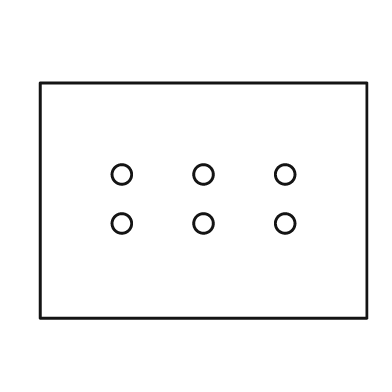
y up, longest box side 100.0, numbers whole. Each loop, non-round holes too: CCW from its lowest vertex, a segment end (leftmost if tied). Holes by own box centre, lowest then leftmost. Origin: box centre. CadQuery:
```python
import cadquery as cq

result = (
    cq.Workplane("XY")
    .moveTo(-50.0, -36.0)
    .lineTo(50.0, -36.0)
    .lineTo(50.0, 36.0)
    .lineTo(-50.0, 36.0)
    .close()
    .moveTo(-25.0, -7.0)
    .circle(3.0)
    .moveTo(0.0, -7.0)
    .circle(3.0)
    .moveTo(25.0, -7.0)
    .circle(3.0)
    .moveTo(-25.0, 8.0)
    .circle(3.0)
    .moveTo(0.0, 8.0)
    .circle(3.0)
    .moveTo(25.0, 8.0)
    .circle(3.0)
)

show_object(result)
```